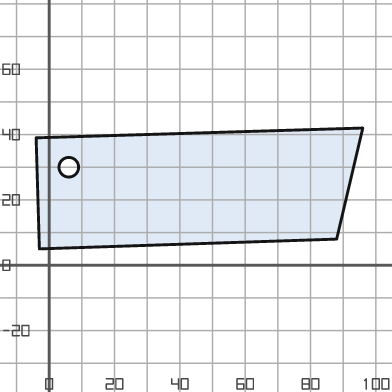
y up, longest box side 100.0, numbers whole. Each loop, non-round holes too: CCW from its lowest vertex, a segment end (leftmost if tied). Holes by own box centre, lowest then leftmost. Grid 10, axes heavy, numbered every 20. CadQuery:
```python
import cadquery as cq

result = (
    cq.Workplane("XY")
    .moveTo(-3.0, 5.0)
    .lineTo(88.0, 8.0)
    .lineTo(96.0, 42.0)
    .lineTo(-4.0, 39.0)
    .close()
    .moveTo(6.0, 30.0)
    .circle(3.0)
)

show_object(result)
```